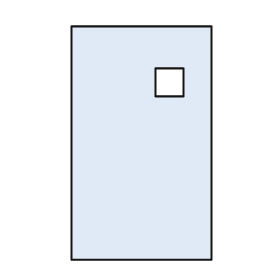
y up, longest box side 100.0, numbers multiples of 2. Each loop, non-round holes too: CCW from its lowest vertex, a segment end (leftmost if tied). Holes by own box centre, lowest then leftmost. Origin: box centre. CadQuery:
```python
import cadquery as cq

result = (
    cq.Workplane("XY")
    .moveTo(-30.0, -50.0)
    .lineTo(30.0, -50.0)
    .lineTo(30.0, 50.0)
    .lineTo(-30.0, 50.0)
    .close()
    .moveTo(6.0, 20.0)
    .lineTo(18.0, 20.0)
    .lineTo(18.0, 32.0)
    .lineTo(6.0, 32.0)
    .close()
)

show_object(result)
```